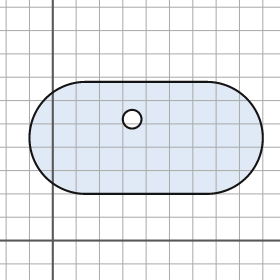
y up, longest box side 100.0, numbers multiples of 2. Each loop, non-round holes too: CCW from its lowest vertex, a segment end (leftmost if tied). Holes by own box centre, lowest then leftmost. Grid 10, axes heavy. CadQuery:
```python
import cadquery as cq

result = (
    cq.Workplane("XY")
    .moveTo(14.0, 20.0)
    .lineTo(66.0, 20.0)
    .threePointArc((90.0, 44.0), (66.0, 68.0))
    .lineTo(14.0, 68.0)
    .threePointArc((-10.0, 44.0), (14.0, 20.0))
    .close()
    .moveTo(34.0, 52.0)
    .circle(4.0)
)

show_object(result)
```